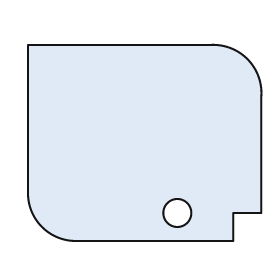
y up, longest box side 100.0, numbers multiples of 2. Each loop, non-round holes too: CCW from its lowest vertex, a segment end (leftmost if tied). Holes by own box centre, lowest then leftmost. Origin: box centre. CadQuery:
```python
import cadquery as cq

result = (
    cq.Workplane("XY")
    .moveTo(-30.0, -42.0)
    .lineTo(38.0, -42.0)
    .lineTo(38.0, -30.0)
    .lineTo(50.0, -30.0)
    .lineTo(50.0, 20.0)
    .threePointArc((44.0, 36.0), (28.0, 42.0))
    .lineTo(-50.0, 42.0)
    .lineTo(-50.0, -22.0)
    .threePointArc((-44.0, -36.0), (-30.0, -42.0))
    .close()
    .moveTo(14.0, -30.0)
    .circle(6.0)
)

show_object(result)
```